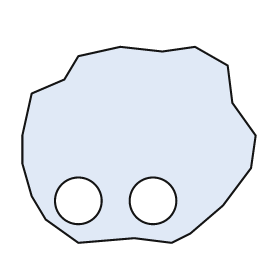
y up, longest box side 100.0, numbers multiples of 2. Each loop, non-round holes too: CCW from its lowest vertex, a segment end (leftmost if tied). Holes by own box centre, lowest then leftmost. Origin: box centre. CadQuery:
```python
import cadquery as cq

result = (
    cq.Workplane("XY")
    .moveTo(-26.0, -42.0)
    .lineTo(-2.0, -40.0)
    .lineTo(14.0, -42.0)
    .lineTo(22.0, -38.0)
    .lineTo(36.0, -26.0)
    .lineTo(48.0, -10.0)
    .lineTo(50.0, 4.0)
    .lineTo(40.0, 18.0)
    .lineTo(38.0, 34.0)
    .lineTo(24.0, 42.0)
    .lineTo(10.0, 40.0)
    .lineTo(-8.0, 42.0)
    .lineTo(-26.0, 38.0)
    .lineTo(-32.0, 28.0)
    .lineTo(-46.0, 22.0)
    .lineTo(-50.0, 4.0)
    .lineTo(-50.0, -8.0)
    .lineTo(-46.0, -22.0)
    .lineTo(-40.0, -32.0)
    .close()
    .moveTo(-26.0, -24.0)
    .circle(10.0)
    .moveTo(6.0, -24.0)
    .circle(10.0)
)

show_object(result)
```